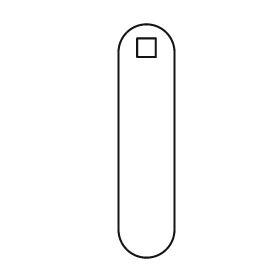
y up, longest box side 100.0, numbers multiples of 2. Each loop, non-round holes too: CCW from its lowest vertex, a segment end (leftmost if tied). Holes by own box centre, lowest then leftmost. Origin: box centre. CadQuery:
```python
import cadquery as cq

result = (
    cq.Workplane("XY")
    .moveTo(-12.0, -38.0)
    .threePointArc((0.0, -50.0), (12.0, -38.0))
    .lineTo(12.0, 38.0)
    .threePointArc((0.0, 50.0), (-12.0, 38.0))
    .close()
    .moveTo(-4.0, 36.0)
    .lineTo(4.0, 36.0)
    .lineTo(4.0, 44.0)
    .lineTo(-4.0, 44.0)
    .close()
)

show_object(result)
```